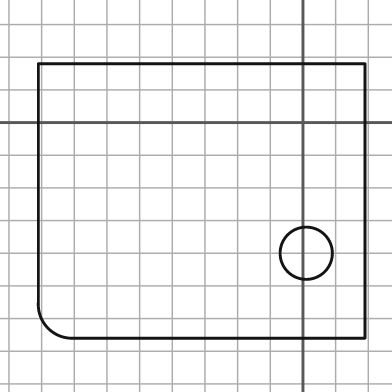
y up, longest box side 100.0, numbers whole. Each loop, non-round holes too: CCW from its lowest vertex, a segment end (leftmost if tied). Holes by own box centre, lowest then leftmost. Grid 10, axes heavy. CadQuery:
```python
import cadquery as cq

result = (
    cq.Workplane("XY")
    .moveTo(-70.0, -66.0)
    .lineTo(19.0, -66.0)
    .lineTo(19.0, 18.0)
    .lineTo(-81.0, 18.0)
    .lineTo(-81.0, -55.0)
    .threePointArc((-78.0, -63.0), (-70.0, -66.0))
    .close()
    .moveTo(1.0, -40.0)
    .circle(8.0)
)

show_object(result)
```